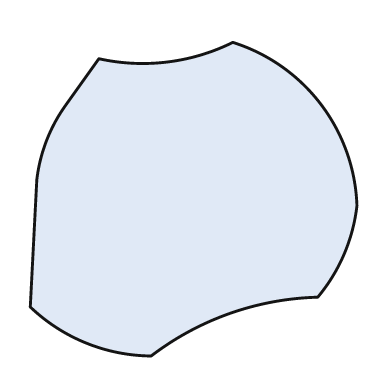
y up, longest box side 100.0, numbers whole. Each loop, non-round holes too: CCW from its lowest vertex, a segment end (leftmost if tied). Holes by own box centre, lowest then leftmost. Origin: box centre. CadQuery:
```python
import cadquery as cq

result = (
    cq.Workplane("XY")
    .moveTo(-13.0, -48.0)
    .threePointArc((11.0, -35.0), (38.0, -30.0))
    .threePointArc((46.0, -17.0), (50.0, -2.0))
    .threePointArc((39.0, 29.0), (12.0, 48.0))
    .threePointArc((-8.0, 42.0), (-29.0, 43.0))
    .lineTo(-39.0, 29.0)
    .threePointArc((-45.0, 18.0), (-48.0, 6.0))
    .lineTo(-50.0, -33.0)
    .threePointArc((-33.0, -44.0), (-13.0, -48.0))
    .close()
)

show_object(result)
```